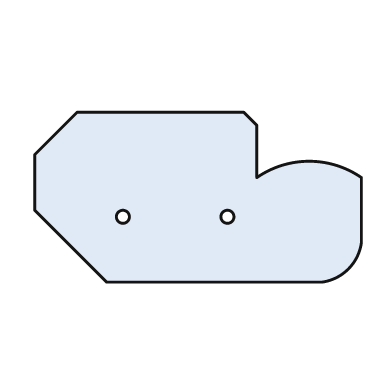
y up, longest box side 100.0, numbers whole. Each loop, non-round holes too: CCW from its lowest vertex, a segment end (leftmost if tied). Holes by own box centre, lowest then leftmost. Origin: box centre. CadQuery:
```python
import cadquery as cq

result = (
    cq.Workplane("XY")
    .moveTo(-28.0, -26.0)
    .lineTo(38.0, -26.0)
    .threePointArc((46.0, -22.0), (50.0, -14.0))
    .lineTo(50.0, 6.0)
    .threePointArc((34.0, 11.0), (18.0, 6.0))
    .lineTo(18.0, 22.0)
    .lineTo(14.0, 26.0)
    .lineTo(-37.0, 26.0)
    .lineTo(-50.0, 13.0)
    .lineTo(-50.0, -4.0)
    .close()
    .moveTo(-23.0, -6.0)
    .circle(2.0)
    .moveTo(9.0, -6.0)
    .circle(2.0)
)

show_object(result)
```